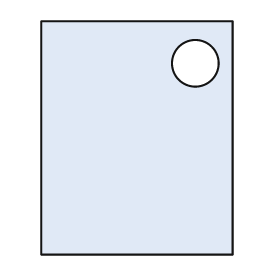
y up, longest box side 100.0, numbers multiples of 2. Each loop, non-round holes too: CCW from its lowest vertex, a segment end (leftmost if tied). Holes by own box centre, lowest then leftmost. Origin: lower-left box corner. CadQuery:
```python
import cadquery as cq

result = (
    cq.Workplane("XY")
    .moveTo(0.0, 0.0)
    .lineTo(82.0, 0.0)
    .lineTo(82.0, 100.0)
    .lineTo(0.0, 100.0)
    .close()
    .moveTo(66.0, 82.0)
    .circle(10.0)
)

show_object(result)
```